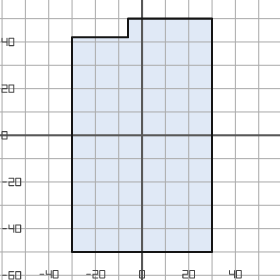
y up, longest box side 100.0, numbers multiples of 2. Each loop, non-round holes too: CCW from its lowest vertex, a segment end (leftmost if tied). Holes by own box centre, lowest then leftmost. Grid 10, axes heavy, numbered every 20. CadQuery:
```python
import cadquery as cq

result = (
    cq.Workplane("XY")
    .moveTo(-30.0, -50.0)
    .lineTo(30.0, -50.0)
    .lineTo(30.0, 50.0)
    .lineTo(-6.0, 50.0)
    .lineTo(-6.0, 42.0)
    .lineTo(-30.0, 42.0)
    .close()
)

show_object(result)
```